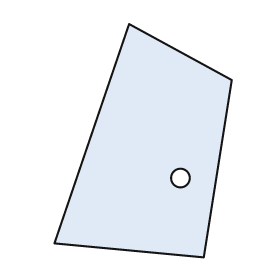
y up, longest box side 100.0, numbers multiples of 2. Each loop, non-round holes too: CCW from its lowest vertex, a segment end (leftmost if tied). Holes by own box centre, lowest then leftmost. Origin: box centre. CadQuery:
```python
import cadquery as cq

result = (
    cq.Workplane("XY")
    .moveTo(26.0, -50.0)
    .lineTo(38.0, 26.0)
    .lineTo(-6.0, 50.0)
    .lineTo(-38.0, -44.0)
    .close()
    .moveTo(16.0, -16.0)
    .circle(4.0)
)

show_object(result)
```